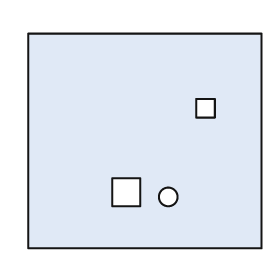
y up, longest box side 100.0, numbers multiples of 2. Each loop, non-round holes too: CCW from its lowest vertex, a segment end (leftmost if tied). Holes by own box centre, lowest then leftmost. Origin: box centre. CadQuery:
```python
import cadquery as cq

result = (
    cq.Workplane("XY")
    .moveTo(-50.0, -46.0)
    .lineTo(50.0, -46.0)
    .lineTo(50.0, 46.0)
    .lineTo(-50.0, 46.0)
    .close()
    .moveTo(10.0, -24.0)
    .circle(4.0)
    .moveTo(-14.0, -28.0)
    .lineTo(-2.0, -28.0)
    .lineTo(-2.0, -16.0)
    .lineTo(-14.0, -16.0)
    .close()
    .moveTo(22.0, 10.0)
    .lineTo(30.0, 10.0)
    .lineTo(30.0, 18.0)
    .lineTo(22.0, 18.0)
    .close()
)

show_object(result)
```